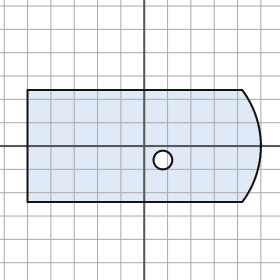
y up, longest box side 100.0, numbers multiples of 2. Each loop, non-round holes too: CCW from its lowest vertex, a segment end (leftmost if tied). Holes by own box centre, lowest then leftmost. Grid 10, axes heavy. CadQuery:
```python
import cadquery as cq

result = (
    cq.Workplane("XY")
    .moveTo(-50.0, -24.0)
    .lineTo(42.0, -24.0)
    .threePointArc((50.0, 0.0), (42.0, 24.0))
    .lineTo(-50.0, 24.0)
    .close()
    .moveTo(8.0, -6.0)
    .circle(4.0)
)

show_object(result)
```